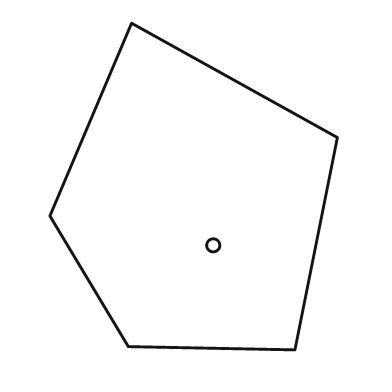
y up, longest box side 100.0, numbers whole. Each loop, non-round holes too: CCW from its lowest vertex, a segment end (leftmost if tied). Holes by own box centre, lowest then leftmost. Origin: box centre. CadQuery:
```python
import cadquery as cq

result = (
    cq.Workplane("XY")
    .moveTo(31.0, -50.0)
    .lineTo(44.0, 15.0)
    .lineTo(-19.0, 50.0)
    .lineTo(-44.0, -9.0)
    .lineTo(-20.0, -49.0)
    .close()
    .moveTo(6.0, -18.0)
    .circle(2.0)
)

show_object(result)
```